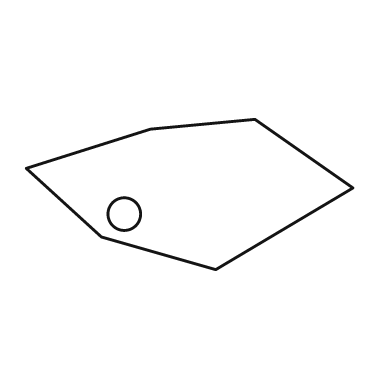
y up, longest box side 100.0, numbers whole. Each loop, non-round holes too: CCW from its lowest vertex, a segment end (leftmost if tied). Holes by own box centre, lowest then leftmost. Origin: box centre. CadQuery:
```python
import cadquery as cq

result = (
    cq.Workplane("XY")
    .moveTo(8.0, -23.0)
    .lineTo(50.0, 2.0)
    .lineTo(20.0, 23.0)
    .lineTo(-12.0, 20.0)
    .lineTo(-50.0, 8.0)
    .lineTo(-27.0, -13.0)
    .close()
    .moveTo(-20.0, -6.0)
    .circle(5.0)
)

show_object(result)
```